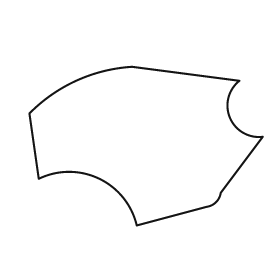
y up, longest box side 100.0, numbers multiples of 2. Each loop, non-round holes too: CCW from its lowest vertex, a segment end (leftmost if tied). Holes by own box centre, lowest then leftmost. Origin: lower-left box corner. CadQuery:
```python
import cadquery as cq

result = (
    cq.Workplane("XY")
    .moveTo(46.0, 0.0)
    .lineTo(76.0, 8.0)
    .threePointArc((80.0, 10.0), (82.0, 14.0))
    .lineTo(100.0, 38.0)
    .threePointArc((86.0, 46.0), (90.0, 62.0))
    .lineTo(44.0, 68.0)
    .threePointArc((20.0, 62.0), (0.0, 48.0))
    .lineTo(4.0, 20.0)
    .threePointArc((30.0, 20.0), (46.0, 0.0))
    .close()
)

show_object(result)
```